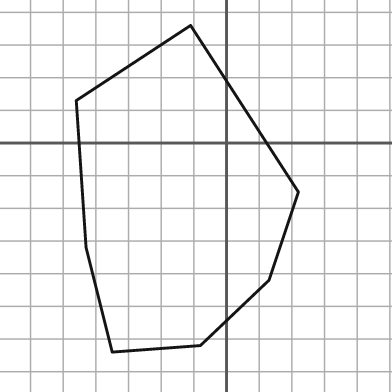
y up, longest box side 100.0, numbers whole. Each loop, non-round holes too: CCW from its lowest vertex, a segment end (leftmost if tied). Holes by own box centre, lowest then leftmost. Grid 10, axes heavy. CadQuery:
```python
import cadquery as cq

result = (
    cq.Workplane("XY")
    .moveTo(-35.0, -64.0)
    .lineTo(-8.0, -62.0)
    .lineTo(13.0, -42.0)
    .lineTo(22.0, -15.0)
    .lineTo(-11.0, 36.0)
    .lineTo(-46.0, 13.0)
    .lineTo(-43.0, -32.0)
    .close()
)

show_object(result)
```